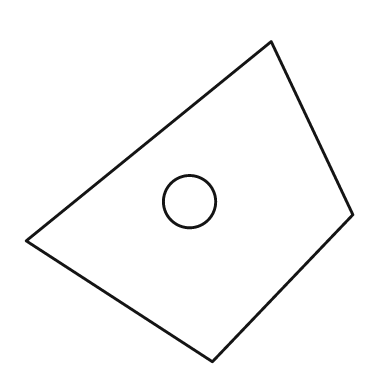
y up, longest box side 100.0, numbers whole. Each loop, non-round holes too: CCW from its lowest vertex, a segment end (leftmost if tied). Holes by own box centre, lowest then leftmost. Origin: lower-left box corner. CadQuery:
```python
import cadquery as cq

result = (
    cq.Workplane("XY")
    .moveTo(57.0, 0.0)
    .lineTo(100.0, 45.0)
    .lineTo(75.0, 98.0)
    .lineTo(0.0, 37.0)
    .close()
    .moveTo(50.0, 49.0)
    .circle(8.0)
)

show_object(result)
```